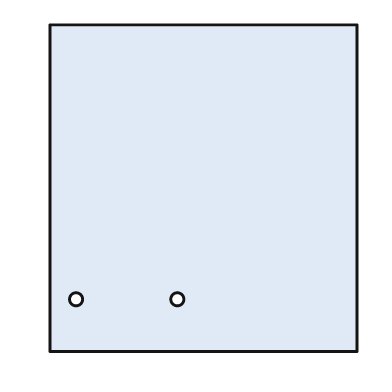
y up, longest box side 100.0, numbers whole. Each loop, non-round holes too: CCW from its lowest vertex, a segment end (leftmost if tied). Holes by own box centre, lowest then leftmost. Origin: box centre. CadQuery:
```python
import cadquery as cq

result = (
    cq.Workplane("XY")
    .moveTo(-47.0, -50.0)
    .lineTo(47.0, -50.0)
    .lineTo(47.0, 50.0)
    .lineTo(-47.0, 50.0)
    .close()
    .moveTo(-39.0, -34.0)
    .circle(2.0)
    .moveTo(-8.0, -34.0)
    .circle(2.0)
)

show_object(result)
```